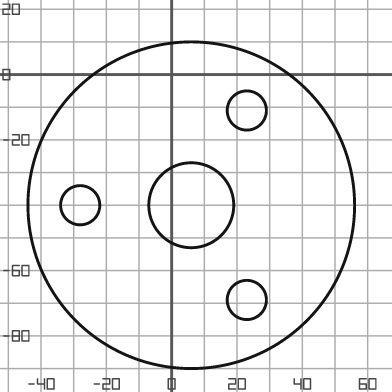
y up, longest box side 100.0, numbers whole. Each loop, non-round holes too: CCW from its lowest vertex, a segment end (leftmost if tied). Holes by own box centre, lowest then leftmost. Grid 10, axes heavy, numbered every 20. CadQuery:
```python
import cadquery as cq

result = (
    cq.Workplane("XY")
    .moveTo(6.0, -40.0)
    .circle(50.0)
    .moveTo(23.0, -69.0)
    .circle(6.0)
    .moveTo(-28.0, -40.0)
    .circle(6.0)
    .moveTo(6.0, -40.0)
    .circle(13.0)
    .moveTo(23.0, -11.0)
    .circle(6.0)
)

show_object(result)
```